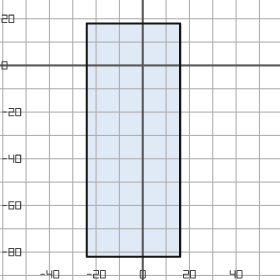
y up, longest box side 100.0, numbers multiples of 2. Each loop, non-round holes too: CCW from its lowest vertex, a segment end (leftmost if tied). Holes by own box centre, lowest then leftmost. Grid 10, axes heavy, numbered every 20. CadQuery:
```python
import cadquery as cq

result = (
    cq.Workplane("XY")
    .moveTo(-24.0, -82.0)
    .lineTo(16.0, -82.0)
    .lineTo(16.0, 18.0)
    .lineTo(-24.0, 18.0)
    .close()
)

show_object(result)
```